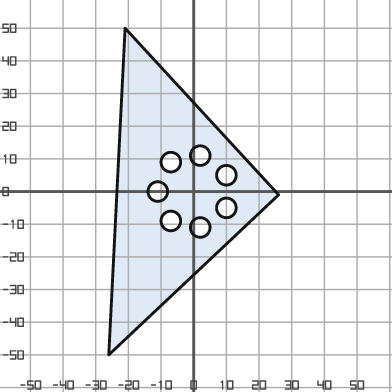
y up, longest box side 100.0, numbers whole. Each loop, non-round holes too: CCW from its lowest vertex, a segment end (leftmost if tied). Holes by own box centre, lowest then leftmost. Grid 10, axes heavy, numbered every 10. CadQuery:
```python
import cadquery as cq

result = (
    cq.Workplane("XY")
    .moveTo(-26.0, -50.0)
    .lineTo(26.0, -1.0)
    .lineTo(-21.0, 50.0)
    .close()
    .moveTo(2.0, -11.0)
    .circle(3.0)
    .moveTo(-7.0, -9.0)
    .circle(3.0)
    .moveTo(10.0, -5.0)
    .circle(3.0)
    .moveTo(-11.0, 0.0)
    .circle(3.0)
    .moveTo(10.0, 5.0)
    .circle(3.0)
    .moveTo(-7.0, 9.0)
    .circle(3.0)
    .moveTo(2.0, 11.0)
    .circle(3.0)
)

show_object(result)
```